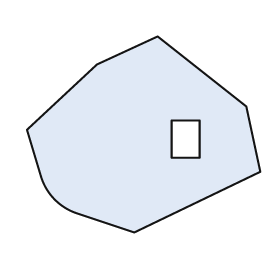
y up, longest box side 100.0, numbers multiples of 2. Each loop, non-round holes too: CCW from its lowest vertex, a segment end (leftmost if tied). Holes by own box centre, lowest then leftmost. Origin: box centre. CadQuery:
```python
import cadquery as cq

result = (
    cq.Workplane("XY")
    .moveTo(-4.0, -42.0)
    .lineTo(50.0, -16.0)
    .lineTo(44.0, 12.0)
    .lineTo(6.0, 42.0)
    .lineTo(-20.0, 30.0)
    .lineTo(-50.0, 2.0)
    .lineTo(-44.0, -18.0)
    .threePointArc((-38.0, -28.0), (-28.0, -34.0))
    .close()
    .moveTo(12.0, -10.0)
    .lineTo(24.0, -10.0)
    .lineTo(24.0, 6.0)
    .lineTo(12.0, 6.0)
    .close()
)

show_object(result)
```